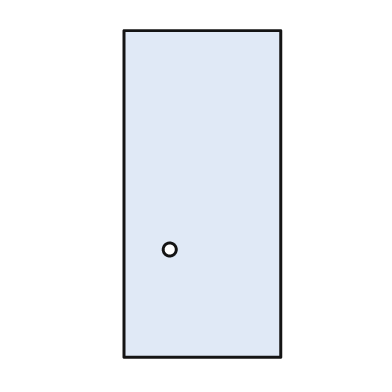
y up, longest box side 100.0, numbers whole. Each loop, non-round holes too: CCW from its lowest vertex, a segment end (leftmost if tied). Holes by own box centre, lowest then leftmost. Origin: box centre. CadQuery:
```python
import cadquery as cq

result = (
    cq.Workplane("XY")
    .moveTo(-24.0, -50.0)
    .lineTo(24.0, -50.0)
    .lineTo(24.0, 50.0)
    .lineTo(-24.0, 50.0)
    .close()
    .moveTo(-10.0, -17.0)
    .circle(2.0)
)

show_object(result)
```